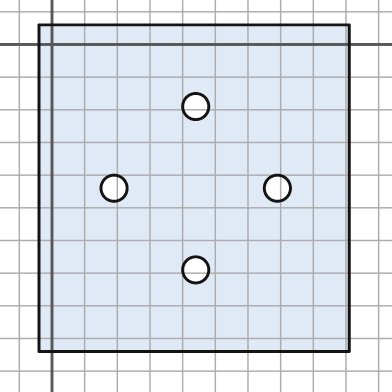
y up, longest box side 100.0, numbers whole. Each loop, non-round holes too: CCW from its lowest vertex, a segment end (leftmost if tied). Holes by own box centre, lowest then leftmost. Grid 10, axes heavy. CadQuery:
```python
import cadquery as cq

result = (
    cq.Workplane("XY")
    .moveTo(-4.0, -94.0)
    .lineTo(91.0, -94.0)
    .lineTo(91.0, 6.0)
    .lineTo(-4.0, 6.0)
    .close()
    .moveTo(44.0, -69.0)
    .circle(4.0)
    .moveTo(19.0, -44.0)
    .circle(4.0)
    .moveTo(69.0, -44.0)
    .circle(4.0)
    .moveTo(44.0, -19.0)
    .circle(4.0)
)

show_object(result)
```